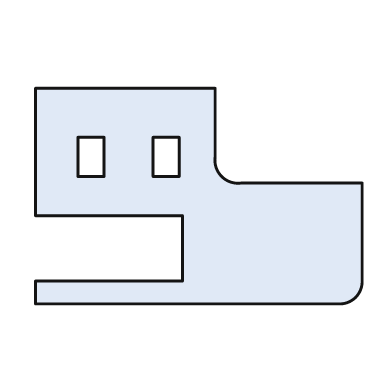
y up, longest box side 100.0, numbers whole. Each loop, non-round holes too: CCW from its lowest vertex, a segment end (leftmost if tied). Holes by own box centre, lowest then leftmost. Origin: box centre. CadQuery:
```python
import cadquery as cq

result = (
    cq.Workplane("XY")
    .moveTo(-50.0, -33.0)
    .lineTo(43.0, -33.0)
    .threePointArc((48.0, -31.0), (50.0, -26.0))
    .lineTo(50.0, 4.0)
    .lineTo(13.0, 4.0)
    .threePointArc((7.0, 6.0), (5.0, 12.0))
    .lineTo(5.0, 33.0)
    .lineTo(-50.0, 33.0)
    .lineTo(-50.0, -6.0)
    .lineTo(-5.0, -6.0)
    .lineTo(-5.0, -26.0)
    .lineTo(-50.0, -26.0)
    .close()
    .moveTo(-37.0, 6.0)
    .lineTo(-29.0, 6.0)
    .lineTo(-29.0, 18.0)
    .lineTo(-37.0, 18.0)
    .close()
    .moveTo(-14.0, 6.0)
    .lineTo(-6.0, 6.0)
    .lineTo(-6.0, 18.0)
    .lineTo(-14.0, 18.0)
    .close()
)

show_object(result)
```